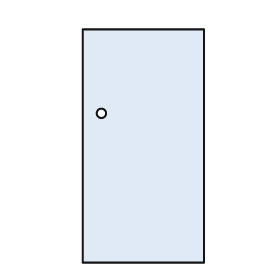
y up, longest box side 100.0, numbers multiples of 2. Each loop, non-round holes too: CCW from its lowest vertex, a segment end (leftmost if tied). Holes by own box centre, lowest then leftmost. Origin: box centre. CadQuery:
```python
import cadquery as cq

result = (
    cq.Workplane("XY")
    .moveTo(-26.0, -50.0)
    .lineTo(26.0, -50.0)
    .lineTo(26.0, 50.0)
    .lineTo(-26.0, 50.0)
    .close()
    .moveTo(-18.0, 14.0)
    .circle(2.0)
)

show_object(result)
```